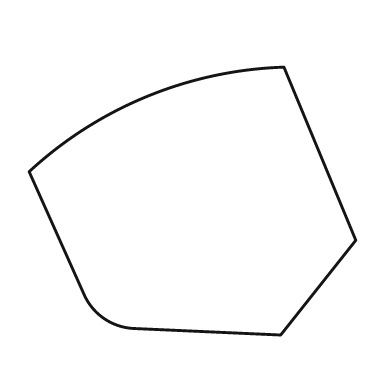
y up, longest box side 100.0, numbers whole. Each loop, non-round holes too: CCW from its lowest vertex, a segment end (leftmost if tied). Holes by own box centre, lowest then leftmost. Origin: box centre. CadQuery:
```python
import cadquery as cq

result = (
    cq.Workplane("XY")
    .moveTo(27.0, -41.0)
    .lineTo(50.0, -12.0)
    .lineTo(28.0, 41.0)
    .threePointArc((-14.0, 32.0), (-50.0, 9.0))
    .lineTo(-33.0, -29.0)
    .threePointArc((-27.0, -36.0), (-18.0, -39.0))
    .close()
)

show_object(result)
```